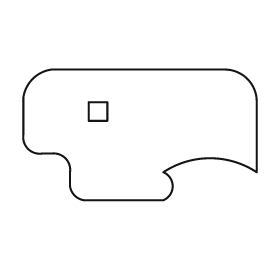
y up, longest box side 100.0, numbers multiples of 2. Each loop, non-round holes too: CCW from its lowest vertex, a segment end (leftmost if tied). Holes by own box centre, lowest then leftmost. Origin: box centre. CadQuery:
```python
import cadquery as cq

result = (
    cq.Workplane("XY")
    .moveTo(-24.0, -28.0)
    .lineTo(10.0, -28.0)
    .threePointArc((14.0, -22.0), (10.0, -16.0))
    .threePointArc((30.0, -10.0), (50.0, -16.0))
    .lineTo(50.0, 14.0)
    .threePointArc((46.0, 24.0), (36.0, 28.0))
    .lineTo(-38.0, 28.0)
    .threePointArc((-46.0, 24.0), (-50.0, 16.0))
    .lineTo(-50.0, 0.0)
    .threePointArc((-48.0, -6.0), (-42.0, -8.0))
    .lineTo(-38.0, -8.0)
    .threePointArc((-32.0, -10.0), (-30.0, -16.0))
    .lineTo(-30.0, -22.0)
    .threePointArc((-28.0, -26.0), (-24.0, -28.0))
    .close()
    .moveTo(-22.0, 6.0)
    .lineTo(-14.0, 6.0)
    .lineTo(-14.0, 14.0)
    .lineTo(-22.0, 14.0)
    .close()
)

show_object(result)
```